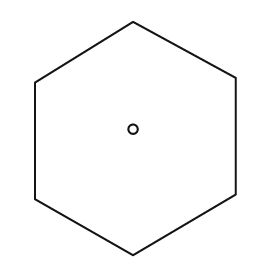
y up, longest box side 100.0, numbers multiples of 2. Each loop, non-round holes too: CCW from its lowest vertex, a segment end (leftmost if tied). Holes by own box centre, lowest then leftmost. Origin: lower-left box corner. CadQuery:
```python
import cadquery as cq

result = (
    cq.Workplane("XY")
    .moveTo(42.0, 0.0)
    .lineTo(86.0, 26.0)
    .lineTo(86.0, 76.0)
    .lineTo(42.0, 100.0)
    .lineTo(0.0, 74.0)
    .lineTo(0.0, 24.0)
    .close()
    .moveTo(42.0, 54.0)
    .circle(2.0)
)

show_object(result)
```